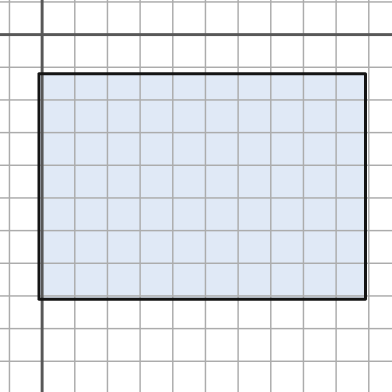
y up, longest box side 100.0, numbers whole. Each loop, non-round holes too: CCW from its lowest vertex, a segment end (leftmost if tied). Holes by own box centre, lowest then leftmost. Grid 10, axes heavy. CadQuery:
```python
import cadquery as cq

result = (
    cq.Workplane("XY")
    .moveTo(-1.0, -81.0)
    .lineTo(99.0, -81.0)
    .lineTo(99.0, -12.0)
    .lineTo(-1.0, -12.0)
    .close()
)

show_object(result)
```